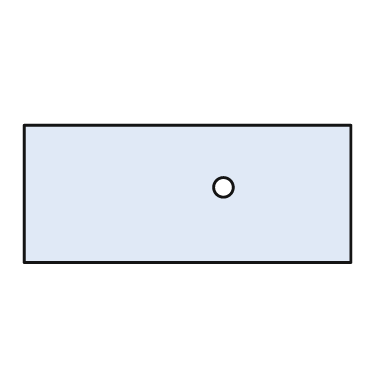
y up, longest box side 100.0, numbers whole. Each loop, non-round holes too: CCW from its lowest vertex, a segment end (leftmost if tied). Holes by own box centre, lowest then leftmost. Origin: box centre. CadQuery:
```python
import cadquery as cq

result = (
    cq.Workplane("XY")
    .moveTo(-50.0, -21.0)
    .lineTo(50.0, -21.0)
    .lineTo(50.0, 21.0)
    .lineTo(-50.0, 21.0)
    .close()
    .moveTo(11.0, 2.0)
    .circle(3.0)
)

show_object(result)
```